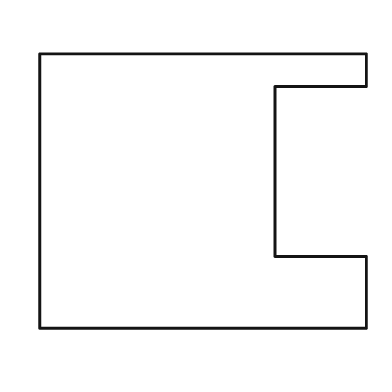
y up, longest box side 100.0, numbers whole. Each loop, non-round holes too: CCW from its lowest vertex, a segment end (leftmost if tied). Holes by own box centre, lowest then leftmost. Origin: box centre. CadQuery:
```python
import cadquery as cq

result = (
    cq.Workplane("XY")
    .moveTo(-50.0, -42.0)
    .lineTo(50.0, -42.0)
    .lineTo(50.0, -20.0)
    .lineTo(22.0, -20.0)
    .lineTo(22.0, 32.0)
    .lineTo(50.0, 32.0)
    .lineTo(50.0, 42.0)
    .lineTo(-50.0, 42.0)
    .close()
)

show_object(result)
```